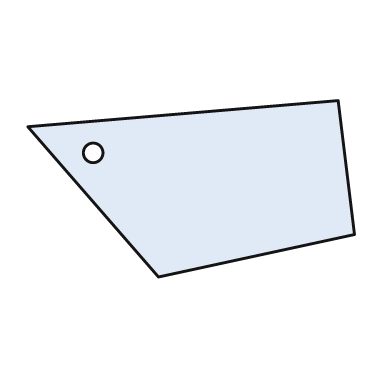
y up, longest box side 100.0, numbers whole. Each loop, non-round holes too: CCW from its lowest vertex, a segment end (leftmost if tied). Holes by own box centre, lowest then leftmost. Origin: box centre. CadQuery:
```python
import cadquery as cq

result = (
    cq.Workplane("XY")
    .moveTo(-10.0, -27.0)
    .lineTo(50.0, -14.0)
    .lineTo(45.0, 27.0)
    .lineTo(-50.0, 19.0)
    .close()
    .moveTo(-30.0, 11.0)
    .circle(3.0)
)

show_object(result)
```